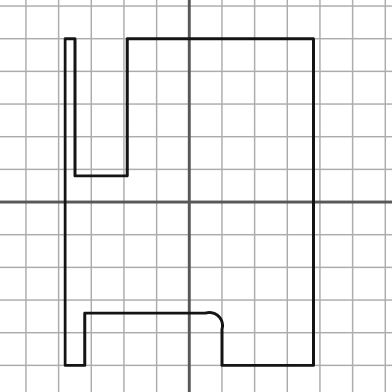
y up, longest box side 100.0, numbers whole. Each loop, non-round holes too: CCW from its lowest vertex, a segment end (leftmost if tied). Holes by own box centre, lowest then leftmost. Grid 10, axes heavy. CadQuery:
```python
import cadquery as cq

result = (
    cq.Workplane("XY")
    .moveTo(-38.0, -50.0)
    .lineTo(-32.0, -50.0)
    .lineTo(-32.0, -34.0)
    .lineTo(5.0, -34.0)
    .threePointArc((9.0, -35.0), (10.0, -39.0))
    .lineTo(10.0, -50.0)
    .lineTo(38.0, -50.0)
    .lineTo(38.0, 50.0)
    .lineTo(-19.0, 50.0)
    .lineTo(-19.0, 8.0)
    .lineTo(-35.0, 8.0)
    .lineTo(-35.0, 50.0)
    .lineTo(-38.0, 50.0)
    .close()
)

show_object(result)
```